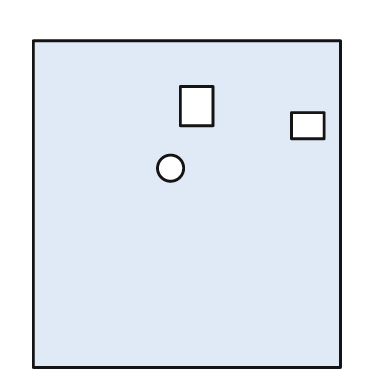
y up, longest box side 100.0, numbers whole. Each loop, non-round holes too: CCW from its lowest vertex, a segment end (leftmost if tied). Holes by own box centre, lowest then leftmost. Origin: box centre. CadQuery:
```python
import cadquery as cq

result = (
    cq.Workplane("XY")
    .moveTo(-47.0, -50.0)
    .lineTo(47.0, -50.0)
    .lineTo(47.0, 50.0)
    .lineTo(-47.0, 50.0)
    .close()
    .moveTo(-5.0, 11.0)
    .circle(4.0)
    .moveTo(32.0, 20.0)
    .lineTo(42.0, 20.0)
    .lineTo(42.0, 28.0)
    .lineTo(32.0, 28.0)
    .close()
    .moveTo(-2.0, 24.0)
    .lineTo(8.0, 24.0)
    .lineTo(8.0, 36.0)
    .lineTo(-2.0, 36.0)
    .close()
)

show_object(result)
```